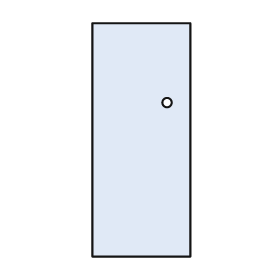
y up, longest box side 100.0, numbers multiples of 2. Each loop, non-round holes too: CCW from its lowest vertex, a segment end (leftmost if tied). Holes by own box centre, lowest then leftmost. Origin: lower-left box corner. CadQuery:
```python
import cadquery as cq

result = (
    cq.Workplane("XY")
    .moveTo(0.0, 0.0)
    .lineTo(42.0, 0.0)
    .lineTo(42.0, 100.0)
    .lineTo(0.0, 100.0)
    .close()
    .moveTo(32.0, 66.0)
    .circle(2.0)
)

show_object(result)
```